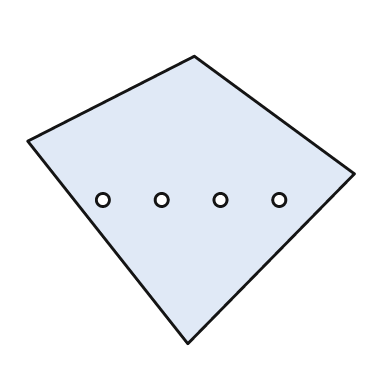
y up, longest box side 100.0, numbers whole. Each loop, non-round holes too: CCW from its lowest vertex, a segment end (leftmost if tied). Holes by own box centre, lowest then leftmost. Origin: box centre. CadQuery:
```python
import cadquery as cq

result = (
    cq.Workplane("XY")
    .moveTo(-1.0, -44.0)
    .lineTo(50.0, 8.0)
    .lineTo(1.0, 44.0)
    .lineTo(-50.0, 18.0)
    .close()
    .moveTo(-27.0, 0.0)
    .circle(2.0)
    .moveTo(-9.0, 0.0)
    .circle(2.0)
    .moveTo(9.0, 0.0)
    .circle(2.0)
    .moveTo(27.0, 0.0)
    .circle(2.0)
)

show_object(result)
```